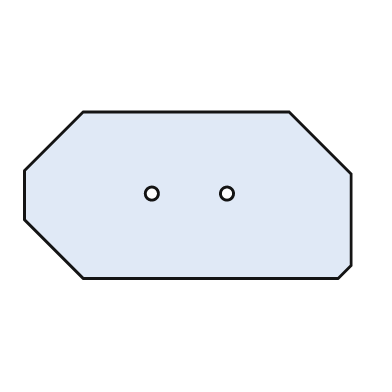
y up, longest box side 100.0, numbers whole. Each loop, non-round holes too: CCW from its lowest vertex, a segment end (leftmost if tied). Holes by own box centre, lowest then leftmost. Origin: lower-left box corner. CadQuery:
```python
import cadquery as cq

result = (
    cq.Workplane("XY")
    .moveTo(18.0, 0.0)
    .lineTo(96.0, 0.0)
    .lineTo(100.0, 4.0)
    .lineTo(100.0, 32.0)
    .lineTo(81.0, 51.0)
    .lineTo(18.0, 51.0)
    .lineTo(0.0, 33.0)
    .lineTo(0.0, 18.0)
    .close()
    .moveTo(39.0, 26.0)
    .circle(2.0)
    .moveTo(62.0, 26.0)
    .circle(2.0)
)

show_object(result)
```